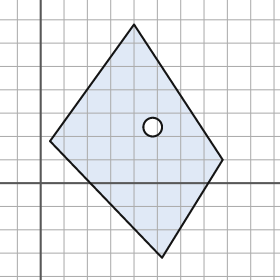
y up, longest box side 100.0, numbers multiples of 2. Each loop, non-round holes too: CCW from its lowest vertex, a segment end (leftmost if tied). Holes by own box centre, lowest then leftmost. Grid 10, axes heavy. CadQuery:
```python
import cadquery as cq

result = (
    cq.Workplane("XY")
    .moveTo(52.0, -32.0)
    .lineTo(78.0, 10.0)
    .lineTo(40.0, 68.0)
    .lineTo(4.0, 18.0)
    .close()
    .moveTo(48.0, 24.0)
    .circle(4.0)
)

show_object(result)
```